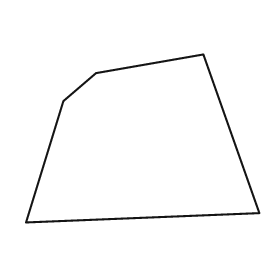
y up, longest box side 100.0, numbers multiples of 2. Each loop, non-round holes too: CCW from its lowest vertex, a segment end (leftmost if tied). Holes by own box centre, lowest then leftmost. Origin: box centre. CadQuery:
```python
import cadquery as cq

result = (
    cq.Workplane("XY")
    .moveTo(-50.0, -36.0)
    .lineTo(50.0, -32.0)
    .lineTo(26.0, 36.0)
    .lineTo(-20.0, 28.0)
    .lineTo(-34.0, 16.0)
    .close()
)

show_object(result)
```